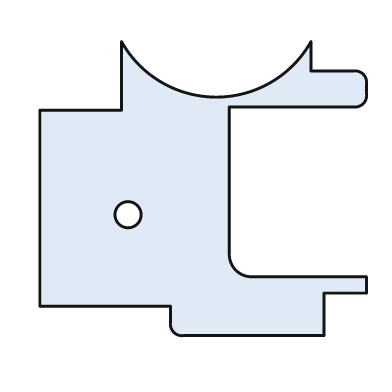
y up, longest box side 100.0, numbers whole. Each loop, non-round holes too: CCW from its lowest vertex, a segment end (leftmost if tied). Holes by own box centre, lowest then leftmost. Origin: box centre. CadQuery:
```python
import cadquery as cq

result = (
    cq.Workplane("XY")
    .moveTo(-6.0, -45.0)
    .lineTo(37.0, -45.0)
    .lineTo(37.0, -32.0)
    .lineTo(50.0, -32.0)
    .lineTo(50.0, -27.0)
    .lineTo(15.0, -27.0)
    .threePointArc((10.0, -25.0), (8.0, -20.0))
    .lineTo(8.0, 25.0)
    .lineTo(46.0, 25.0)
    .threePointArc((49.0, 26.0), (50.0, 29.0))
    .lineTo(50.0, 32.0)
    .threePointArc((49.0, 35.0), (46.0, 36.0))
    .lineTo(33.0, 36.0)
    .lineTo(33.0, 45.0)
    .threePointArc((4.0, 28.0), (-25.0, 45.0))
    .lineTo(-25.0, 24.0)
    .lineTo(-50.0, 24.0)
    .lineTo(-50.0, -36.0)
    .lineTo(-10.0, -36.0)
    .lineTo(-10.0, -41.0)
    .threePointArc((-9.0, -44.0), (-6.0, -45.0))
    .close()
    .moveTo(-23.0, -8.0)
    .circle(4.0)
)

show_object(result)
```